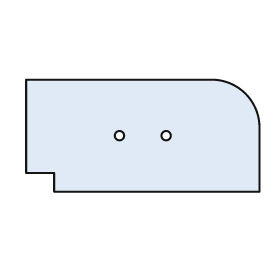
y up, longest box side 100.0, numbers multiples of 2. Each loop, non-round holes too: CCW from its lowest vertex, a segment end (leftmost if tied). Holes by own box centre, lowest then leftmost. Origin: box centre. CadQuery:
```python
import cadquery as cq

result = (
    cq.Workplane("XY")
    .moveTo(-38.0, -24.0)
    .lineTo(50.0, -24.0)
    .lineTo(50.0, 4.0)
    .threePointArc((44.0, 18.0), (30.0, 24.0))
    .lineTo(-50.0, 24.0)
    .lineTo(-50.0, -16.0)
    .lineTo(-38.0, -16.0)
    .close()
    .moveTo(-10.0, 0.0)
    .circle(2.0)
    .moveTo(10.0, 0.0)
    .circle(2.0)
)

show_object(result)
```